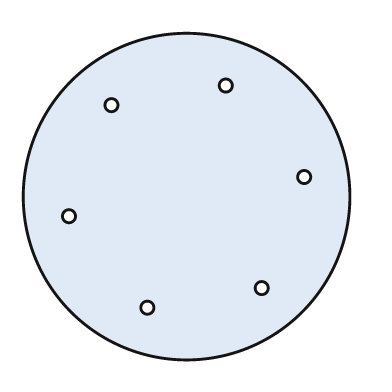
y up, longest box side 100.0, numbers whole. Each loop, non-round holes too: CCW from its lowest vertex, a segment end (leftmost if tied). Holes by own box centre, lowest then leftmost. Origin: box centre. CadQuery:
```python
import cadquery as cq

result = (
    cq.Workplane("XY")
    .moveTo(0.0, 0.0)
    .circle(50.0)
    .moveTo(-12.0, -34.0)
    .circle(2.0)
    .moveTo(23.0, -28.0)
    .circle(2.0)
    .moveTo(-36.0, -6.0)
    .circle(2.0)
    .moveTo(36.0, 6.0)
    .circle(2.0)
    .moveTo(-23.0, 28.0)
    .circle(2.0)
    .moveTo(12.0, 34.0)
    .circle(2.0)
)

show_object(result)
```